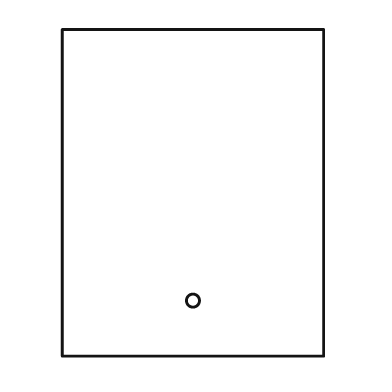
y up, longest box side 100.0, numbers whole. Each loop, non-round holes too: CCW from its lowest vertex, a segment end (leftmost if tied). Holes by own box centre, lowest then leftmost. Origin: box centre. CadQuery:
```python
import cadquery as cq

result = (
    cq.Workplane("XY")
    .moveTo(-40.0, -50.0)
    .lineTo(40.0, -50.0)
    .lineTo(40.0, 50.0)
    .lineTo(-40.0, 50.0)
    .close()
    .moveTo(0.0, -33.0)
    .circle(2.0)
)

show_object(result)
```